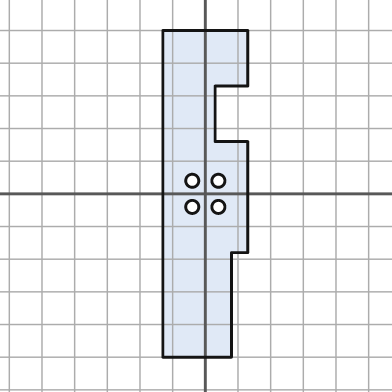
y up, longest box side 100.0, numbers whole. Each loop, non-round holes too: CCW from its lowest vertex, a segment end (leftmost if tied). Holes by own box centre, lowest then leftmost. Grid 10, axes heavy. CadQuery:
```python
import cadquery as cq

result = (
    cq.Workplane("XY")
    .moveTo(-13.0, -50.0)
    .lineTo(8.0, -50.0)
    .lineTo(8.0, -18.0)
    .lineTo(13.0, -18.0)
    .lineTo(13.0, 16.0)
    .lineTo(3.0, 16.0)
    .lineTo(3.0, 33.0)
    .lineTo(13.0, 33.0)
    .lineTo(13.0, 50.0)
    .lineTo(-13.0, 50.0)
    .close()
    .moveTo(-4.0, -4.0)
    .circle(2.0)
    .moveTo(4.0, -4.0)
    .circle(2.0)
    .moveTo(-4.0, 4.0)
    .circle(2.0)
    .moveTo(4.0, 4.0)
    .circle(2.0)
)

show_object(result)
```